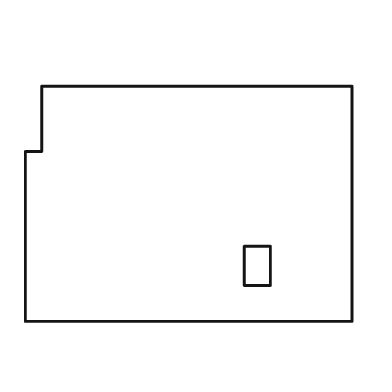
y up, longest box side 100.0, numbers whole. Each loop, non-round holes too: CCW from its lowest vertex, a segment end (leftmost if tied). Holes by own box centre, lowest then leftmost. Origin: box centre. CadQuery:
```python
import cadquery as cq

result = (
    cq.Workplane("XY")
    .moveTo(-50.0, -36.0)
    .lineTo(50.0, -36.0)
    .lineTo(50.0, 36.0)
    .lineTo(-45.0, 36.0)
    .lineTo(-45.0, 16.0)
    .lineTo(-50.0, 16.0)
    .close()
    .moveTo(17.0, -25.0)
    .lineTo(25.0, -25.0)
    .lineTo(25.0, -13.0)
    .lineTo(17.0, -13.0)
    .close()
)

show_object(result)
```